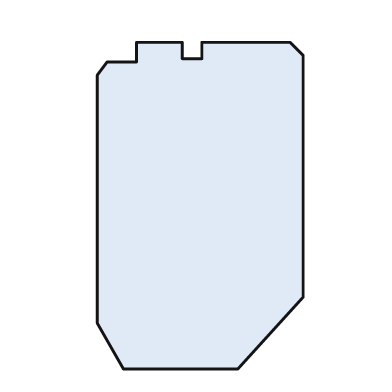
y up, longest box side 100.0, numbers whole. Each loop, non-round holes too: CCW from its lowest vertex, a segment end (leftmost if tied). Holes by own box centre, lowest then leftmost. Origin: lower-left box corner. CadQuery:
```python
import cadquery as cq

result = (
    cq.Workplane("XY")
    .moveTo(8.0, 0.0)
    .lineTo(43.0, 0.0)
    .lineTo(63.0, 22.0)
    .lineTo(63.0, 96.0)
    .lineTo(59.0, 100.0)
    .lineTo(32.0, 100.0)
    .lineTo(32.0, 95.0)
    .lineTo(26.0, 95.0)
    .lineTo(26.0, 100.0)
    .lineTo(12.0, 100.0)
    .lineTo(12.0, 94.0)
    .lineTo(3.0, 94.0)
    .lineTo(0.0, 90.0)
    .lineTo(0.0, 14.0)
    .close()
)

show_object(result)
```